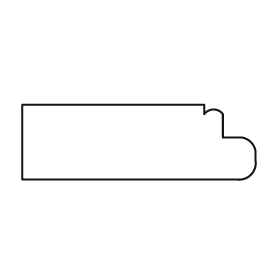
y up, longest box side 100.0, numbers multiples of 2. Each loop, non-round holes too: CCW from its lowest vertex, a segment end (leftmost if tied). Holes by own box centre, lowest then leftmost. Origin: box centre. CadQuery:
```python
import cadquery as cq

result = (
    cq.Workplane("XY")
    .moveTo(-50.0, -16.0)
    .lineTo(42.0, -16.0)
    .threePointArc((48.0, -14.0), (50.0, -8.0))
    .lineTo(50.0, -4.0)
    .threePointArc((48.0, 0.0), (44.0, 2.0))
    .lineTo(36.0, 2.0)
    .lineTo(36.0, 12.0)
    .threePointArc((32.0, 14.0), (28.0, 12.0))
    .lineTo(28.0, 16.0)
    .lineTo(-50.0, 16.0)
    .close()
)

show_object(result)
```